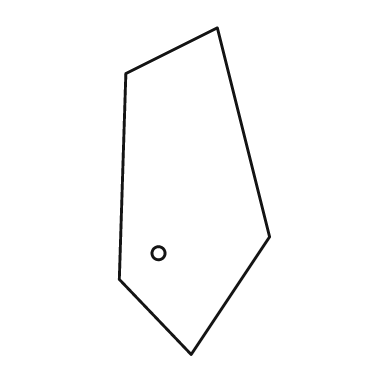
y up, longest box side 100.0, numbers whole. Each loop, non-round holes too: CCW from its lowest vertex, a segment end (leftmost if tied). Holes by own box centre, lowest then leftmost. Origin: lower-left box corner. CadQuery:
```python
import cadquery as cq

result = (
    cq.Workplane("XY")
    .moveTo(22.0, 0.0)
    .lineTo(46.0, 36.0)
    .lineTo(30.0, 100.0)
    .lineTo(2.0, 86.0)
    .lineTo(0.0, 23.0)
    .close()
    .moveTo(12.0, 31.0)
    .circle(2.0)
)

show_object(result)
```